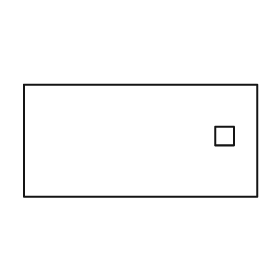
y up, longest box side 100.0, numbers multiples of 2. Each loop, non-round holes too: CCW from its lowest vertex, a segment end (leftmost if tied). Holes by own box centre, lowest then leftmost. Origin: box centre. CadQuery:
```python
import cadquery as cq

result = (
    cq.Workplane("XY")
    .moveTo(-50.0, -24.0)
    .lineTo(50.0, -24.0)
    .lineTo(50.0, 24.0)
    .lineTo(-50.0, 24.0)
    .close()
    .moveTo(32.0, -2.0)
    .lineTo(40.0, -2.0)
    .lineTo(40.0, 6.0)
    .lineTo(32.0, 6.0)
    .close()
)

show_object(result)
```